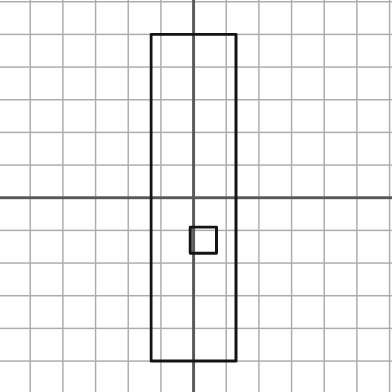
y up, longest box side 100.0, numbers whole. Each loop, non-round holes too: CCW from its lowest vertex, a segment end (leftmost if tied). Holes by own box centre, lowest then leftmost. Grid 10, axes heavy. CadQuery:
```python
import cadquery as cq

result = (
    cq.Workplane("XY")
    .moveTo(-13.0, -50.0)
    .lineTo(13.0, -50.0)
    .lineTo(13.0, 50.0)
    .lineTo(-13.0, 50.0)
    .close()
    .moveTo(-1.0, -17.0)
    .lineTo(7.0, -17.0)
    .lineTo(7.0, -9.0)
    .lineTo(-1.0, -9.0)
    .close()
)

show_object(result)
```